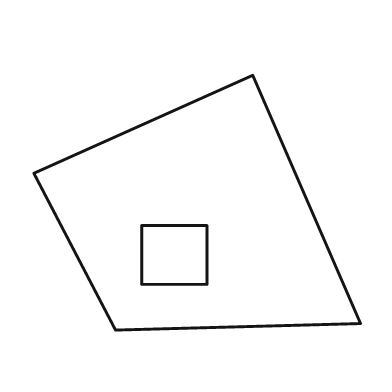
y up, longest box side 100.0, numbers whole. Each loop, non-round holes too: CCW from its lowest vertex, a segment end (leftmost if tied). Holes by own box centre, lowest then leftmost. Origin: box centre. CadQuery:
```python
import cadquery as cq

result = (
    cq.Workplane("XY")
    .moveTo(-25.0, -39.0)
    .lineTo(50.0, -37.0)
    .lineTo(17.0, 39.0)
    .lineTo(-50.0, 9.0)
    .close()
    .moveTo(-17.0, -25.0)
    .lineTo(3.0, -25.0)
    .lineTo(3.0, -7.0)
    .lineTo(-17.0, -7.0)
    .close()
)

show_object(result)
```